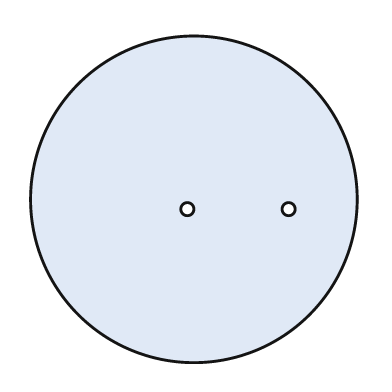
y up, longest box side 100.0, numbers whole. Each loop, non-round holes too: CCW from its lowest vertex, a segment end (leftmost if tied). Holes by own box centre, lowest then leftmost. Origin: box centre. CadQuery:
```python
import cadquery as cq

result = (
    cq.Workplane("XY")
    .moveTo(0.0, 0.0)
    .circle(50.0)
    .moveTo(-2.0, -3.0)
    .circle(2.0)
    .moveTo(29.0, -3.0)
    .circle(2.0)
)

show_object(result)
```